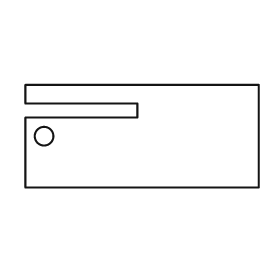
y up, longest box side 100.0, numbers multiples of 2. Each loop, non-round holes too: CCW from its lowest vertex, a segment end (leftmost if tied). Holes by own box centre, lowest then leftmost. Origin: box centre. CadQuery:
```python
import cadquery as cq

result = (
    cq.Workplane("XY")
    .moveTo(-50.0, -22.0)
    .lineTo(50.0, -22.0)
    .lineTo(50.0, 22.0)
    .lineTo(-50.0, 22.0)
    .lineTo(-50.0, 14.0)
    .lineTo(-2.0, 14.0)
    .lineTo(-2.0, 8.0)
    .lineTo(-50.0, 8.0)
    .close()
    .moveTo(-42.0, 0.0)
    .circle(4.0)
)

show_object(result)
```